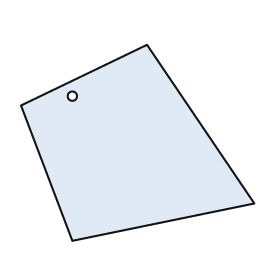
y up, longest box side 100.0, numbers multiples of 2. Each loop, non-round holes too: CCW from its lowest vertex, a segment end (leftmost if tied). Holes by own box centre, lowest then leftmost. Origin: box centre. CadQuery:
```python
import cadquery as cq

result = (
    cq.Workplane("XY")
    .moveTo(-28.0, -42.0)
    .lineTo(50.0, -26.0)
    .lineTo(4.0, 42.0)
    .lineTo(-50.0, 16.0)
    .close()
    .moveTo(-28.0, 20.0)
    .circle(2.0)
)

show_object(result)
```